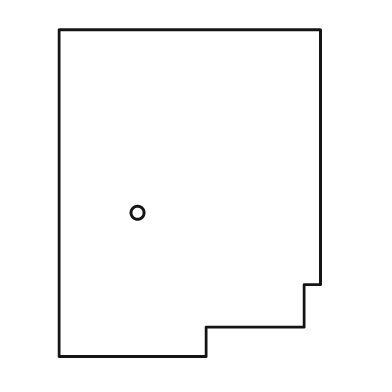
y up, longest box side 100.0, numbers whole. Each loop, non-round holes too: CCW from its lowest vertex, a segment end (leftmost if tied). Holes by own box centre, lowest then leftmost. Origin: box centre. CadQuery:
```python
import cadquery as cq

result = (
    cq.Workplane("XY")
    .moveTo(-40.0, -50.0)
    .lineTo(5.0, -50.0)
    .lineTo(5.0, -41.0)
    .lineTo(35.0, -41.0)
    .lineTo(35.0, -28.0)
    .lineTo(40.0, -28.0)
    .lineTo(40.0, 50.0)
    .lineTo(-40.0, 50.0)
    .close()
    .moveTo(-16.0, -6.0)
    .circle(2.0)
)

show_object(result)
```